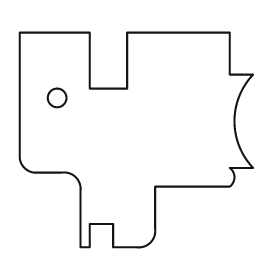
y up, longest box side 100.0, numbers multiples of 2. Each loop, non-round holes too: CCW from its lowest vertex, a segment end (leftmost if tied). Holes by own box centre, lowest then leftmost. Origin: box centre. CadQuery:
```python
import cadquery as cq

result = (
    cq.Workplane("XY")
    .moveTo(-24.0, -46.0)
    .lineTo(-20.0, -46.0)
    .lineTo(-20.0, -36.0)
    .lineTo(-10.0, -36.0)
    .lineTo(-10.0, -46.0)
    .lineTo(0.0, -46.0)
    .threePointArc((6.0, -44.0), (8.0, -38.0))
    .lineTo(8.0, -20.0)
    .lineTo(40.0, -20.0)
    .threePointArc((42.0, -16.0), (40.0, -12.0))
    .lineTo(50.0, -12.0)
    .threePointArc((42.0, 8.0), (50.0, 28.0))
    .lineTo(40.0, 28.0)
    .lineTo(40.0, 46.0)
    .lineTo(-4.0, 46.0)
    .lineTo(-4.0, 22.0)
    .lineTo(-20.0, 22.0)
    .lineTo(-20.0, 46.0)
    .lineTo(-50.0, 46.0)
    .lineTo(-50.0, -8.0)
    .threePointArc((-48.0, -12.0), (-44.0, -14.0))
    .lineTo(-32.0, -14.0)
    .threePointArc((-26.0, -16.0), (-24.0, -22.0))
    .close()
    .moveTo(-34.0, 18.0)
    .circle(4.0)
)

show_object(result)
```